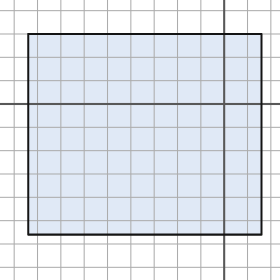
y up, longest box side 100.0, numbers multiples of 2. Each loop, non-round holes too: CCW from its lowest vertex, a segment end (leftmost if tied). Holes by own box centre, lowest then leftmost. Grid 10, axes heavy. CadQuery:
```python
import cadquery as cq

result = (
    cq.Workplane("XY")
    .moveTo(-84.0, -56.0)
    .lineTo(16.0, -56.0)
    .lineTo(16.0, 30.0)
    .lineTo(-84.0, 30.0)
    .close()
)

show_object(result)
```